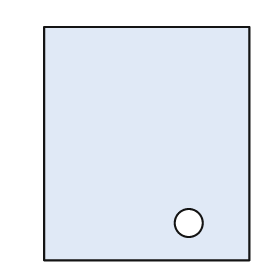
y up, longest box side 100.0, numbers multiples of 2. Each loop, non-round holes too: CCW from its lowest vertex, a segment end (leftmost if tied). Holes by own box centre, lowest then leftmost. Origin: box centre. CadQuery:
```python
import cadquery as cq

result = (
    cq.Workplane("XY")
    .moveTo(-44.0, -50.0)
    .lineTo(44.0, -50.0)
    .lineTo(44.0, 50.0)
    .lineTo(-44.0, 50.0)
    .close()
    .moveTo(18.0, -34.0)
    .circle(6.0)
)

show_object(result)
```